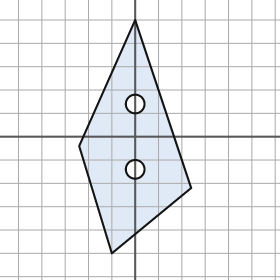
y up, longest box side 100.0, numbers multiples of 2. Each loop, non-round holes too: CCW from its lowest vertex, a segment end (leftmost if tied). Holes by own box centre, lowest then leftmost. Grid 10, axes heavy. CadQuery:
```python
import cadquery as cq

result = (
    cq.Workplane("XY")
    .moveTo(-10.0, -50.0)
    .lineTo(24.0, -22.0)
    .lineTo(0.0, 50.0)
    .lineTo(-24.0, -4.0)
    .close()
    .moveTo(0.0, -14.0)
    .circle(4.0)
    .moveTo(0.0, 14.0)
    .circle(4.0)
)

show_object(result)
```